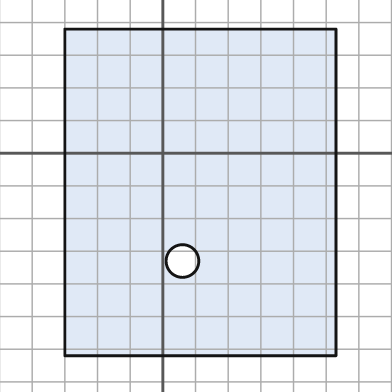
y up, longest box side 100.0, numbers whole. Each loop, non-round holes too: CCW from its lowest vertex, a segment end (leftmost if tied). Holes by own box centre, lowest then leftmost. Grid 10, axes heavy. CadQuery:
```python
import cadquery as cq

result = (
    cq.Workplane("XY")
    .moveTo(-30.0, -62.0)
    .lineTo(53.0, -62.0)
    .lineTo(53.0, 38.0)
    .lineTo(-30.0, 38.0)
    .close()
    .moveTo(6.0, -33.0)
    .circle(5.0)
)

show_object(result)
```